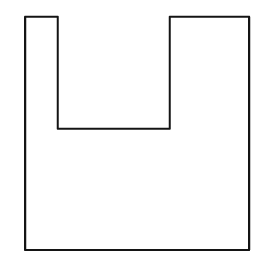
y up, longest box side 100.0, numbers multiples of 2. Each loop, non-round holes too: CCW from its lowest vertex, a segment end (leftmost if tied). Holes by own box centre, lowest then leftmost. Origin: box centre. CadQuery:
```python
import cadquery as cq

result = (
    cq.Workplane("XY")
    .moveTo(-48.0, -50.0)
    .lineTo(48.0, -50.0)
    .lineTo(48.0, 50.0)
    .lineTo(14.0, 50.0)
    .lineTo(14.0, 2.0)
    .lineTo(-34.0, 2.0)
    .lineTo(-34.0, 50.0)
    .lineTo(-48.0, 50.0)
    .close()
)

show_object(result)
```